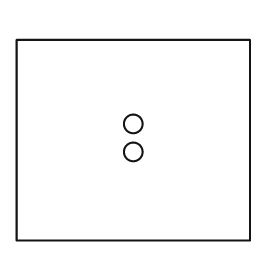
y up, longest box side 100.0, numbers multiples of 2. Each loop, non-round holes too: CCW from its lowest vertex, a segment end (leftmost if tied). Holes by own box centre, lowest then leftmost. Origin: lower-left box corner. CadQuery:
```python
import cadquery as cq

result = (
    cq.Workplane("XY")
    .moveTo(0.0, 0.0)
    .lineTo(100.0, 0.0)
    .lineTo(100.0, 86.0)
    .lineTo(0.0, 86.0)
    .close()
    .moveTo(50.0, 38.0)
    .circle(4.0)
    .moveTo(50.0, 50.0)
    .circle(4.0)
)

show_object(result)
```